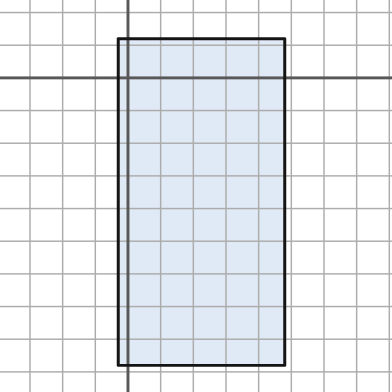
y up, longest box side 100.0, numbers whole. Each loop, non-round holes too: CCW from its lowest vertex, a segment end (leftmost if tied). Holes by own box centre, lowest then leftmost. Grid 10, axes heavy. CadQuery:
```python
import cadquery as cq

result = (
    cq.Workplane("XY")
    .moveTo(-3.0, -88.0)
    .lineTo(48.0, -88.0)
    .lineTo(48.0, 12.0)
    .lineTo(-3.0, 12.0)
    .close()
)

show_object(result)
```